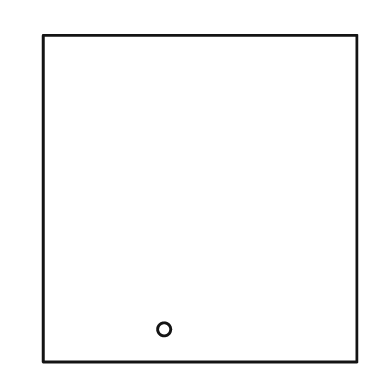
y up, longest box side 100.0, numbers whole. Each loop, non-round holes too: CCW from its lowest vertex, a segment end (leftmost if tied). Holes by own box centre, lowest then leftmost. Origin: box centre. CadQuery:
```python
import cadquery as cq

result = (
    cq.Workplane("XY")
    .moveTo(-48.0, -50.0)
    .lineTo(48.0, -50.0)
    .lineTo(48.0, 50.0)
    .lineTo(-48.0, 50.0)
    .close()
    .moveTo(-11.0, -40.0)
    .circle(2.0)
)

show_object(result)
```